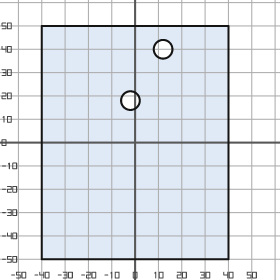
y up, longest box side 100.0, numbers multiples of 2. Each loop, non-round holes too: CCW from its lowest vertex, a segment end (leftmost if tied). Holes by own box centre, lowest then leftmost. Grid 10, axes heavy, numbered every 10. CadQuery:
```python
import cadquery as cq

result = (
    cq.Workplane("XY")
    .moveTo(-40.0, -50.0)
    .lineTo(40.0, -50.0)
    .lineTo(40.0, 50.0)
    .lineTo(-40.0, 50.0)
    .close()
    .moveTo(-2.0, 18.0)
    .circle(4.0)
    .moveTo(12.0, 40.0)
    .circle(4.0)
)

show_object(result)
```